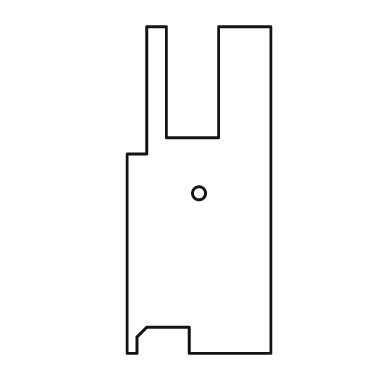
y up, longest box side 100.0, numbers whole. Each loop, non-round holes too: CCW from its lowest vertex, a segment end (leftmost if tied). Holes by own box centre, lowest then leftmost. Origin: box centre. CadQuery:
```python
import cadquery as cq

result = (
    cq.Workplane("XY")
    .moveTo(-22.0, -50.0)
    .lineTo(-19.0, -50.0)
    .lineTo(-19.0, -45.0)
    .lineTo(-16.0, -42.0)
    .lineTo(-3.0, -42.0)
    .lineTo(-3.0, -50.0)
    .lineTo(22.0, -50.0)
    .lineTo(22.0, 50.0)
    .lineTo(6.0, 50.0)
    .lineTo(6.0, 16.0)
    .lineTo(-10.0, 16.0)
    .lineTo(-10.0, 50.0)
    .lineTo(-16.0, 50.0)
    .lineTo(-16.0, 11.0)
    .lineTo(-22.0, 11.0)
    .close()
    .moveTo(0.0, -1.0)
    .circle(2.0)
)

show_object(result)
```